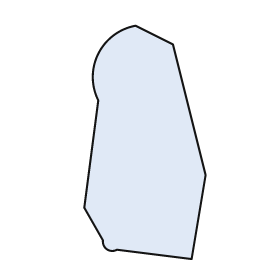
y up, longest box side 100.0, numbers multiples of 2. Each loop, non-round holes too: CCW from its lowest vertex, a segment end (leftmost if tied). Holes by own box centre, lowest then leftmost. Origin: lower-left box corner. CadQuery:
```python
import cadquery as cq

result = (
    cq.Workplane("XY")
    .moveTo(46.0, 0.0)
    .lineTo(52.0, 36.0)
    .lineTo(38.0, 92.0)
    .lineTo(22.0, 100.0)
    .threePointArc((6.0, 88.0), (6.0, 68.0))
    .lineTo(0.0, 22.0)
    .lineTo(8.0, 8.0)
    .threePointArc((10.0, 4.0), (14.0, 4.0))
    .close()
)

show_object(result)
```